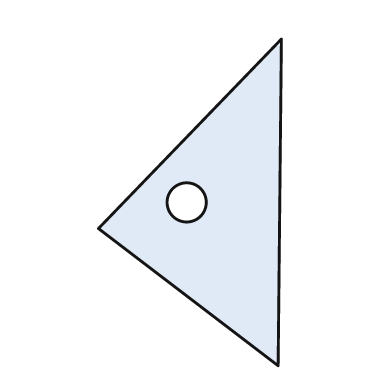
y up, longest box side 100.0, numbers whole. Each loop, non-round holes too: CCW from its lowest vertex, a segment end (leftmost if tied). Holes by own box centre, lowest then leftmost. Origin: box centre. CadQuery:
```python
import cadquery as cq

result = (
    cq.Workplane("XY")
    .moveTo(27.0, -50.0)
    .lineTo(28.0, 50.0)
    .lineTo(-28.0, -8.0)
    .close()
    .moveTo(-1.0, 0.0)
    .circle(6.0)
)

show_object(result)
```